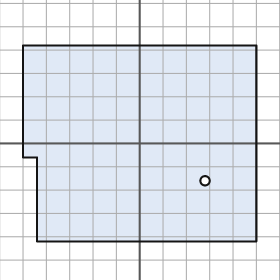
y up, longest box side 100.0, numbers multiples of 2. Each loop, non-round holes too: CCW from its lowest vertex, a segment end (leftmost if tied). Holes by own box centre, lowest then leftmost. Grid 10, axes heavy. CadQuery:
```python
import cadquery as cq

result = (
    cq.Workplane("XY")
    .moveTo(-44.0, -42.0)
    .lineTo(50.0, -42.0)
    .lineTo(50.0, 42.0)
    .lineTo(-50.0, 42.0)
    .lineTo(-50.0, -6.0)
    .lineTo(-44.0, -6.0)
    .close()
    .moveTo(28.0, -16.0)
    .circle(2.0)
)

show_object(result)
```